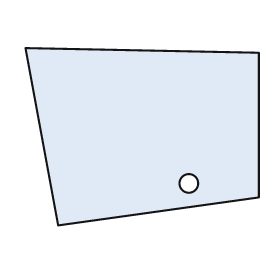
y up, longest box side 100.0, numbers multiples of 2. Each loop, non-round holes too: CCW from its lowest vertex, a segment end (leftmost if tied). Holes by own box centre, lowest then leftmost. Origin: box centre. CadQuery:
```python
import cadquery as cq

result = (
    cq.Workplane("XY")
    .moveTo(-36.0, -38.0)
    .lineTo(50.0, -26.0)
    .lineTo(50.0, 36.0)
    .lineTo(-50.0, 38.0)
    .close()
    .moveTo(20.0, -20.0)
    .circle(4.0)
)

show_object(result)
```